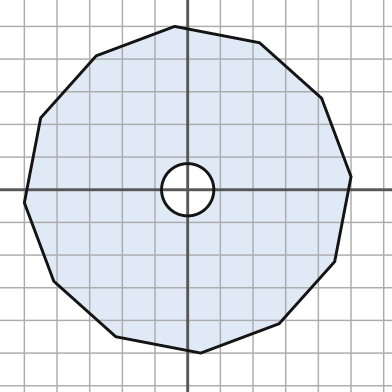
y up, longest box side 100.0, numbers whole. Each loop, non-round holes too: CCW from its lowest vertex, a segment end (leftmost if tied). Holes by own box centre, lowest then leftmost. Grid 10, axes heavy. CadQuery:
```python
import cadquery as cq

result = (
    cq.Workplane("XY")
    .moveTo(4.0, -50.0)
    .lineTo(28.0, -41.0)
    .lineTo(45.0, -22.0)
    .lineTo(50.0, 4.0)
    .lineTo(41.0, 28.0)
    .lineTo(22.0, 45.0)
    .lineTo(-4.0, 50.0)
    .lineTo(-28.0, 41.0)
    .lineTo(-45.0, 22.0)
    .lineTo(-50.0, -4.0)
    .lineTo(-41.0, -28.0)
    .lineTo(-22.0, -45.0)
    .close()
    .moveTo(0.0, 0.0)
    .circle(8.0)
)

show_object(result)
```